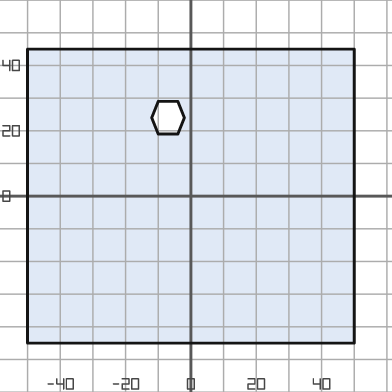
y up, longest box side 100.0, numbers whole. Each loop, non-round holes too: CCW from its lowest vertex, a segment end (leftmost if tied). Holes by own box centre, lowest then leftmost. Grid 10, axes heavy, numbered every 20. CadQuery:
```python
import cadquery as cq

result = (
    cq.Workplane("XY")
    .moveTo(-50.0, -45.0)
    .lineTo(50.0, -45.0)
    .lineTo(50.0, 45.0)
    .lineTo(-50.0, 45.0)
    .close()
    .moveTo(-10.0, 19.0)
    .lineTo(-4.0, 19.0)
    .lineTo(-2.0, 24.0)
    .lineTo(-4.0, 29.0)
    .lineTo(-10.0, 29.0)
    .lineTo(-12.0, 24.0)
    .close()
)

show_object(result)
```